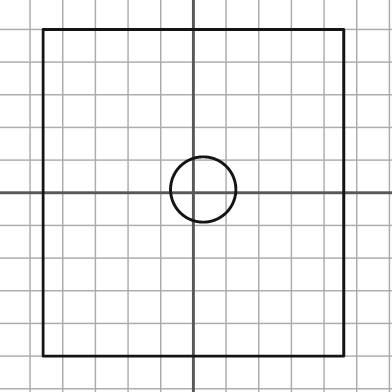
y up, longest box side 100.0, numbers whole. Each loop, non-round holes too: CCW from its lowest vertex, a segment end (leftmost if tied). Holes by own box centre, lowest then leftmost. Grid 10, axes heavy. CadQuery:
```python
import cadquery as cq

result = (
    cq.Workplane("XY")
    .moveTo(-46.0, -50.0)
    .lineTo(46.0, -50.0)
    .lineTo(46.0, 50.0)
    .lineTo(-46.0, 50.0)
    .close()
    .moveTo(3.0, 1.0)
    .circle(10.0)
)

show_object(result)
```